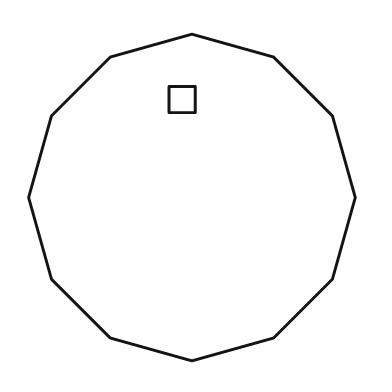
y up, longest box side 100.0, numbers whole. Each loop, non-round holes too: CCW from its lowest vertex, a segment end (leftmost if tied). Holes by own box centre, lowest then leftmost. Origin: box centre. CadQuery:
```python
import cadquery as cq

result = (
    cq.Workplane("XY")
    .moveTo(0.0, -50.0)
    .lineTo(25.0, -43.0)
    .lineTo(43.0, -25.0)
    .lineTo(50.0, 0.0)
    .lineTo(43.0, 25.0)
    .lineTo(25.0, 43.0)
    .lineTo(0.0, 50.0)
    .lineTo(-25.0, 43.0)
    .lineTo(-43.0, 25.0)
    .lineTo(-50.0, 0.0)
    .lineTo(-43.0, -25.0)
    .lineTo(-25.0, -43.0)
    .close()
    .moveTo(-7.0, 26.0)
    .lineTo(1.0, 26.0)
    .lineTo(1.0, 34.0)
    .lineTo(-7.0, 34.0)
    .close()
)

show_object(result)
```